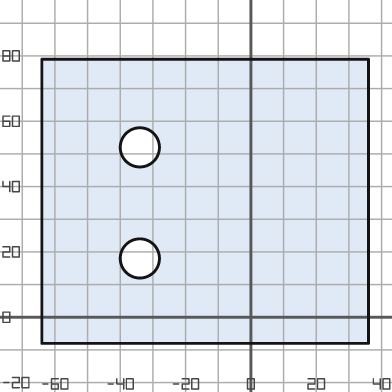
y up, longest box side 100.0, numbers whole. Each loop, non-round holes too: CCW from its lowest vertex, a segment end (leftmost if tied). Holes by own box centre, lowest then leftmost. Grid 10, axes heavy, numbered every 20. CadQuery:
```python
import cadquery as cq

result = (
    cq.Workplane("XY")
    .moveTo(-64.0, -8.0)
    .lineTo(36.0, -8.0)
    .lineTo(36.0, 79.0)
    .lineTo(-64.0, 79.0)
    .close()
    .moveTo(-34.0, 18.0)
    .circle(6.0)
    .moveTo(-34.0, 52.0)
    .circle(6.0)
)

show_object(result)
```